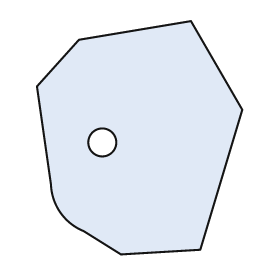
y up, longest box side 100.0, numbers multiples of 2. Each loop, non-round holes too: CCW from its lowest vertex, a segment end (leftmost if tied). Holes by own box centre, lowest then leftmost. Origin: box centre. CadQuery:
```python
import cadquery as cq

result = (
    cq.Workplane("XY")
    .moveTo(-8.0, -50.0)
    .lineTo(26.0, -48.0)
    .lineTo(44.0, 12.0)
    .lineTo(22.0, 50.0)
    .lineTo(-26.0, 42.0)
    .lineTo(-44.0, 22.0)
    .lineTo(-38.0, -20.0)
    .threePointArc((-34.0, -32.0), (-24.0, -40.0))
    .close()
    .moveTo(-16.0, -2.0)
    .circle(6.0)
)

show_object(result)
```